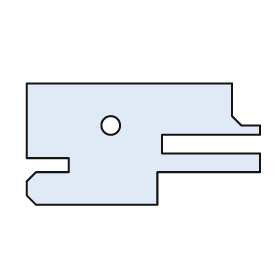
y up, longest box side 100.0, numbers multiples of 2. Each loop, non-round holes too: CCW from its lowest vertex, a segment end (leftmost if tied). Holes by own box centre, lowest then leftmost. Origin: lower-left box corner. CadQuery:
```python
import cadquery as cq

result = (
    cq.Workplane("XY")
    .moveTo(4.0, 0.0)
    .lineTo(56.0, 0.0)
    .lineTo(56.0, 14.0)
    .lineTo(100.0, 14.0)
    .lineTo(100.0, 22.0)
    .lineTo(58.0, 22.0)
    .lineTo(58.0, 30.0)
    .lineTo(100.0, 30.0)
    .lineTo(100.0, 34.0)
    .lineTo(92.0, 34.0)
    .lineTo(88.0, 38.0)
    .lineTo(88.0, 52.0)
    .lineTo(0.0, 52.0)
    .lineTo(0.0, 20.0)
    .lineTo(18.0, 20.0)
    .lineTo(18.0, 14.0)
    .lineTo(4.0, 14.0)
    .lineTo(0.0, 10.0)
    .lineTo(0.0, 4.0)
    .close()
    .moveTo(36.0, 34.0)
    .circle(4.0)
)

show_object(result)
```